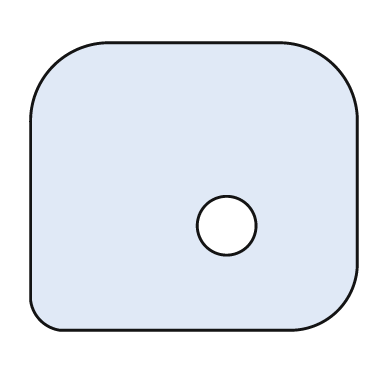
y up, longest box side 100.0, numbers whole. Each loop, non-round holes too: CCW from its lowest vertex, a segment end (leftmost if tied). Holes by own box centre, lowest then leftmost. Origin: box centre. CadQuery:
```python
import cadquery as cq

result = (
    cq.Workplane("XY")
    .moveTo(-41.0, -44.0)
    .lineTo(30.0, -44.0)
    .threePointArc((44.0, -38.0), (50.0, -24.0))
    .lineTo(50.0, 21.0)
    .threePointArc((43.0, 37.0), (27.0, 44.0))
    .lineTo(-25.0, 44.0)
    .threePointArc((-43.0, 37.0), (-50.0, 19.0))
    .lineTo(-50.0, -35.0)
    .threePointArc((-47.0, -41.0), (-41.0, -44.0))
    .close()
    .moveTo(10.0, -12.0)
    .circle(9.0)
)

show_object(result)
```